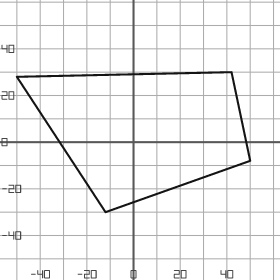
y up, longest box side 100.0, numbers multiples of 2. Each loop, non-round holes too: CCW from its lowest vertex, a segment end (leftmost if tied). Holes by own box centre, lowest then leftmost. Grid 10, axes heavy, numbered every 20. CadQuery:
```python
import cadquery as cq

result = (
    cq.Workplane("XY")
    .moveTo(-12.0, -30.0)
    .lineTo(50.0, -8.0)
    .lineTo(42.0, 30.0)
    .lineTo(-50.0, 28.0)
    .close()
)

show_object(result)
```